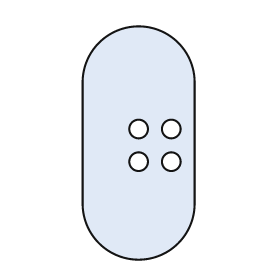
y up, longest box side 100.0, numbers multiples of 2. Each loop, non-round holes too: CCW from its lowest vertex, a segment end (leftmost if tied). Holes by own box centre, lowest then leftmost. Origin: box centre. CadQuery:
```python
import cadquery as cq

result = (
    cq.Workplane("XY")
    .moveTo(-24.0, -26.0)
    .threePointArc((0.0, -50.0), (24.0, -26.0))
    .lineTo(24.0, 26.0)
    .threePointArc((0.0, 50.0), (-24.0, 26.0))
    .close()
    .moveTo(0.0, -8.0)
    .circle(4.0)
    .moveTo(14.0, -8.0)
    .circle(4.0)
    .moveTo(0.0, 6.0)
    .circle(4.0)
    .moveTo(14.0, 6.0)
    .circle(4.0)
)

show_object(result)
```